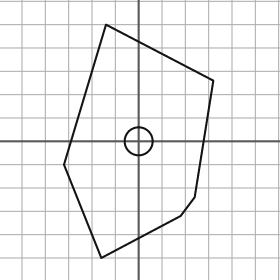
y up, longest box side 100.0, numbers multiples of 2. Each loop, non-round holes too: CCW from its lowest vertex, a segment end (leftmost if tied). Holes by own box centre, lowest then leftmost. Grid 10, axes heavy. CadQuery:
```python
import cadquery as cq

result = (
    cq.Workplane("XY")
    .moveTo(-16.0, -50.0)
    .lineTo(18.0, -32.0)
    .lineTo(24.0, -24.0)
    .lineTo(32.0, 26.0)
    .lineTo(-14.0, 50.0)
    .lineTo(-32.0, -10.0)
    .close()
    .moveTo(0.0, 0.0)
    .circle(6.0)
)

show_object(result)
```